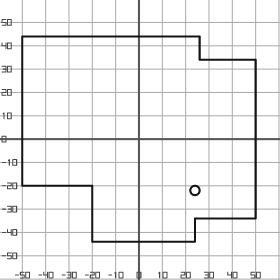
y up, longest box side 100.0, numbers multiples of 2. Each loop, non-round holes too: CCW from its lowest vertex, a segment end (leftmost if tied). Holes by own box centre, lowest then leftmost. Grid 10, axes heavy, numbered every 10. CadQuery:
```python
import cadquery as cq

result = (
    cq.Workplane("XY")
    .moveTo(-20.0, -44.0)
    .lineTo(24.0, -44.0)
    .lineTo(24.0, -34.0)
    .lineTo(50.0, -34.0)
    .lineTo(50.0, 34.0)
    .lineTo(26.0, 34.0)
    .lineTo(26.0, 44.0)
    .lineTo(-50.0, 44.0)
    .lineTo(-50.0, -20.0)
    .lineTo(-20.0, -20.0)
    .close()
    .moveTo(24.0, -22.0)
    .circle(2.0)
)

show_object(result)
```